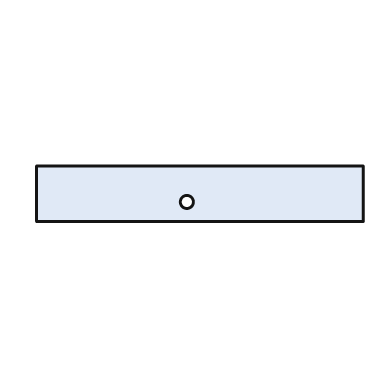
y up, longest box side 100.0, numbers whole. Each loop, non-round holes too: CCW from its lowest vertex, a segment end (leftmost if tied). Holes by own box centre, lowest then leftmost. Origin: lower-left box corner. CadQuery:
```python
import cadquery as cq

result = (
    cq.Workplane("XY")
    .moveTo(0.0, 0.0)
    .lineTo(100.0, 0.0)
    .lineTo(100.0, 17.0)
    .lineTo(0.0, 17.0)
    .close()
    .moveTo(46.0, 6.0)
    .circle(2.0)
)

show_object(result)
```